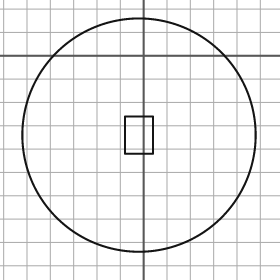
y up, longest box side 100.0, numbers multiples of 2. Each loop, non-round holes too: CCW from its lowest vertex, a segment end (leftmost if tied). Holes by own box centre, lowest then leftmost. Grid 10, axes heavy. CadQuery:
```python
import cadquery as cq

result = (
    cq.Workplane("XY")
    .moveTo(-2.0, -34.0)
    .circle(50.0)
    .moveTo(-8.0, -42.0)
    .lineTo(4.0, -42.0)
    .lineTo(4.0, -26.0)
    .lineTo(-8.0, -26.0)
    .close()
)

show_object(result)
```